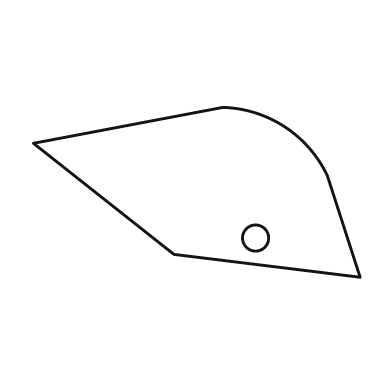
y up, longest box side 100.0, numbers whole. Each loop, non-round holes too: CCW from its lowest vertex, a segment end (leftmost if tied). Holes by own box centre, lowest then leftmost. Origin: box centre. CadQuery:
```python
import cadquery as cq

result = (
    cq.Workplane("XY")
    .moveTo(50.0, -26.0)
    .lineTo(40.0, 5.0)
    .threePointArc((27.0, 20.0), (8.0, 26.0))
    .lineTo(-50.0, 15.0)
    .lineTo(-7.0, -19.0)
    .close()
    .moveTo(18.0, -14.0)
    .circle(4.0)
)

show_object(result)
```